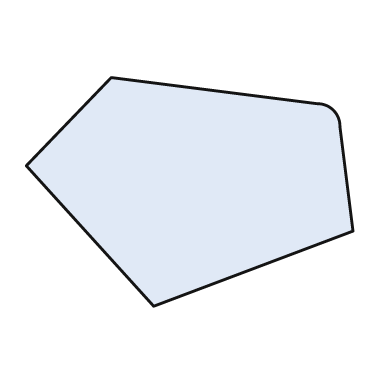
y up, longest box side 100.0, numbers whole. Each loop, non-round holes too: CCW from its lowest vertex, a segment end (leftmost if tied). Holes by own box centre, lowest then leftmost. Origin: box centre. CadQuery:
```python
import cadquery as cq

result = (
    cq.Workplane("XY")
    .moveTo(-11.0, -35.0)
    .lineTo(50.0, -12.0)
    .lineTo(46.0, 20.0)
    .threePointArc((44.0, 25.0), (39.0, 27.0))
    .lineTo(-24.0, 35.0)
    .lineTo(-50.0, 8.0)
    .close()
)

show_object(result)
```